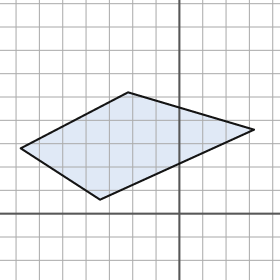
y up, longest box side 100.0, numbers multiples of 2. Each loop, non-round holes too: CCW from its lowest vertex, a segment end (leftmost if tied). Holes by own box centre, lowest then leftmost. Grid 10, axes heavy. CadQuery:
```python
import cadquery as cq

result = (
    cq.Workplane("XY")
    .moveTo(-34.0, 6.0)
    .lineTo(32.0, 36.0)
    .lineTo(-22.0, 52.0)
    .lineTo(-68.0, 28.0)
    .close()
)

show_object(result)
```